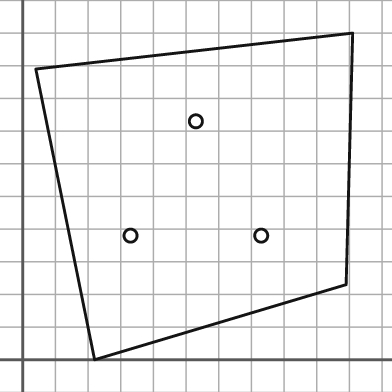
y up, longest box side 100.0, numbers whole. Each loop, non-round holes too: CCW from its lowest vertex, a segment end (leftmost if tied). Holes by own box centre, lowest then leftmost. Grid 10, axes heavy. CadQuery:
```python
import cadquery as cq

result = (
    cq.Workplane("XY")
    .moveTo(22.0, 0.0)
    .lineTo(99.0, 23.0)
    .lineTo(101.0, 100.0)
    .lineTo(4.0, 89.0)
    .close()
    .moveTo(33.0, 38.0)
    .circle(2.0)
    .moveTo(73.0, 38.0)
    .circle(2.0)
    .moveTo(53.0, 73.0)
    .circle(2.0)
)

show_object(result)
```